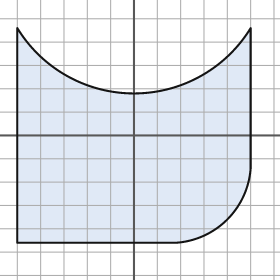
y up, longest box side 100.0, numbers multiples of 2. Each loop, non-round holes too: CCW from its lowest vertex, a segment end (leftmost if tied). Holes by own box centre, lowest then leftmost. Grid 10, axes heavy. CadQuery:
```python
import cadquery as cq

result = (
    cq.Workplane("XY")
    .moveTo(-50.0, -46.0)
    .lineTo(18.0, -46.0)
    .threePointArc((40.0, -36.0), (50.0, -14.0))
    .lineTo(50.0, 46.0)
    .threePointArc((0.0, 18.0), (-50.0, 46.0))
    .close()
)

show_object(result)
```